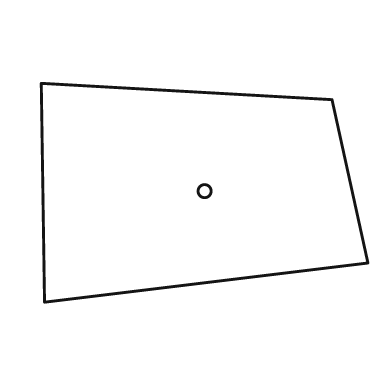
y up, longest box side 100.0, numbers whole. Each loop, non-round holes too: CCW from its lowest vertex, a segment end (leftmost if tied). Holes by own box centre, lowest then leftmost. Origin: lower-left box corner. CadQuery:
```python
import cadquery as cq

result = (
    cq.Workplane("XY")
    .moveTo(1.0, 0.0)
    .lineTo(100.0, 12.0)
    .lineTo(89.0, 62.0)
    .lineTo(0.0, 67.0)
    .close()
    .moveTo(50.0, 34.0)
    .circle(2.0)
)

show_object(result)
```